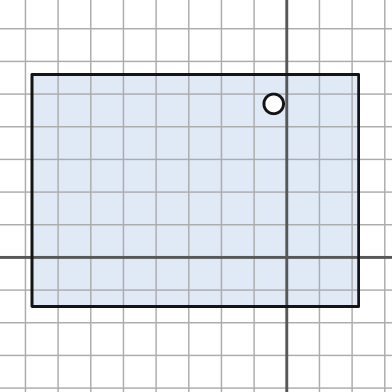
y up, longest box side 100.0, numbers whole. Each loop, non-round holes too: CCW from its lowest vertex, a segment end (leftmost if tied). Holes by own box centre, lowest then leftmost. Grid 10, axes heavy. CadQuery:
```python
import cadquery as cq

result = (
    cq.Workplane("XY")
    .moveTo(-78.0, -15.0)
    .lineTo(22.0, -15.0)
    .lineTo(22.0, 56.0)
    .lineTo(-78.0, 56.0)
    .close()
    .moveTo(-4.0, 47.0)
    .circle(3.0)
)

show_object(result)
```